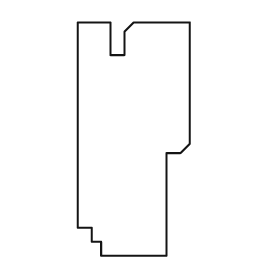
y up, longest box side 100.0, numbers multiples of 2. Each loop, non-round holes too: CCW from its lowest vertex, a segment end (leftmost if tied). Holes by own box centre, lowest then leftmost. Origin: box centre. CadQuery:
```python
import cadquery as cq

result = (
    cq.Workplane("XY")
    .moveTo(-14.0, -50.0)
    .lineTo(14.0, -50.0)
    .lineTo(14.0, -6.0)
    .lineTo(20.0, -6.0)
    .lineTo(24.0, -2.0)
    .lineTo(24.0, 50.0)
    .lineTo(0.0, 50.0)
    .lineTo(-4.0, 46.0)
    .lineTo(-4.0, 36.0)
    .lineTo(-10.0, 36.0)
    .lineTo(-10.0, 50.0)
    .lineTo(-24.0, 50.0)
    .lineTo(-24.0, -38.0)
    .lineTo(-18.0, -38.0)
    .lineTo(-18.0, -44.0)
    .lineTo(-14.0, -44.0)
    .close()
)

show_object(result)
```